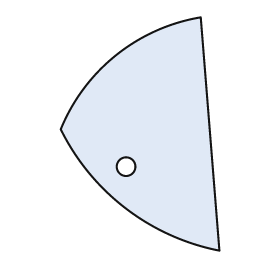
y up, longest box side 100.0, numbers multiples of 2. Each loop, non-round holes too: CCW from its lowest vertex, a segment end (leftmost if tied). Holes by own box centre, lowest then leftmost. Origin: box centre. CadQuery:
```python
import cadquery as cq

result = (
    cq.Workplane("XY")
    .moveTo(34.0, -50.0)
    .lineTo(26.0, 50.0)
    .threePointArc((-10.0, 34.0), (-34.0, 2.0))
    .threePointArc((-6.0, -32.0), (34.0, -50.0))
    .close()
    .moveTo(-6.0, -14.0)
    .circle(4.0)
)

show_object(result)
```